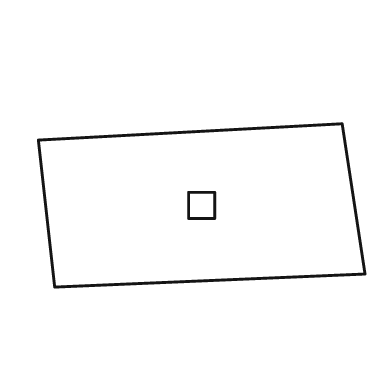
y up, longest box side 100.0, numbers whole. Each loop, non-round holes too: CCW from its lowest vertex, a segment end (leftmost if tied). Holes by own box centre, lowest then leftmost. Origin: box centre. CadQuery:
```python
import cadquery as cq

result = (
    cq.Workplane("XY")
    .moveTo(-45.0, -25.0)
    .lineTo(50.0, -21.0)
    .lineTo(43.0, 25.0)
    .lineTo(-50.0, 20.0)
    .close()
    .moveTo(-4.0, -4.0)
    .lineTo(4.0, -4.0)
    .lineTo(4.0, 4.0)
    .lineTo(-4.0, 4.0)
    .close()
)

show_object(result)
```